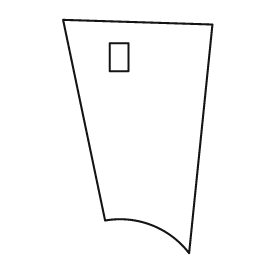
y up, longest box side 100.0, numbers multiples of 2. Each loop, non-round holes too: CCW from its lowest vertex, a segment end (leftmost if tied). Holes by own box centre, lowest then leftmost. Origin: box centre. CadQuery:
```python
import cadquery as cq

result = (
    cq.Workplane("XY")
    .moveTo(22.0, -50.0)
    .lineTo(32.0, 48.0)
    .lineTo(-32.0, 50.0)
    .lineTo(-14.0, -36.0)
    .threePointArc((6.0, -38.0), (22.0, -50.0))
    .close()
    .moveTo(-12.0, 28.0)
    .lineTo(-4.0, 28.0)
    .lineTo(-4.0, 40.0)
    .lineTo(-12.0, 40.0)
    .close()
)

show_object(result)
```